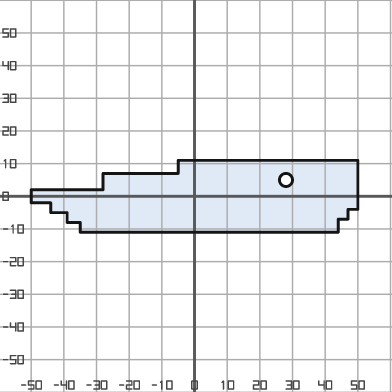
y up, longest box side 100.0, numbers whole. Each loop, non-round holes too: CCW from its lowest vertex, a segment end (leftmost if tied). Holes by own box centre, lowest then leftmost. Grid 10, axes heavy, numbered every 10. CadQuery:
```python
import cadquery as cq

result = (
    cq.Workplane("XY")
    .moveTo(-35.0, -11.0)
    .lineTo(44.0, -11.0)
    .lineTo(44.0, -7.0)
    .lineTo(47.0, -7.0)
    .lineTo(47.0, -4.0)
    .lineTo(50.0, -4.0)
    .lineTo(50.0, 11.0)
    .lineTo(-5.0, 11.0)
    .lineTo(-5.0, 7.0)
    .lineTo(-28.0, 7.0)
    .lineTo(-28.0, 2.0)
    .lineTo(-50.0, 2.0)
    .lineTo(-50.0, -2.0)
    .lineTo(-44.0, -2.0)
    .lineTo(-44.0, -5.0)
    .lineTo(-39.0, -5.0)
    .lineTo(-39.0, -8.0)
    .lineTo(-35.0, -8.0)
    .close()
    .moveTo(28.0, 5.0)
    .circle(2.0)
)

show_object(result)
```